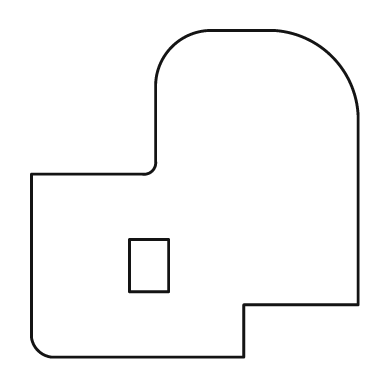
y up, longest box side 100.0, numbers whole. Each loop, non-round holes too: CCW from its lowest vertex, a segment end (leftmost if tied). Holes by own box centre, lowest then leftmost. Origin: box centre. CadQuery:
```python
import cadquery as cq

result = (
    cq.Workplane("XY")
    .moveTo(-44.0, -50.0)
    .lineTo(15.0, -50.0)
    .lineTo(15.0, -34.0)
    .lineTo(50.0, -34.0)
    .lineTo(50.0, 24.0)
    .threePointArc((42.0, 42.0), (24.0, 50.0))
    .lineTo(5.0, 50.0)
    .threePointArc((-7.0, 45.0), (-12.0, 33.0))
    .lineTo(-12.0, 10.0)
    .threePointArc((-13.0, 7.0), (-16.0, 6.0))
    .lineTo(-50.0, 6.0)
    .lineTo(-50.0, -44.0)
    .threePointArc((-48.0, -48.0), (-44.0, -50.0))
    .close()
    .moveTo(-20.0, -30.0)
    .lineTo(-8.0, -30.0)
    .lineTo(-8.0, -14.0)
    .lineTo(-20.0, -14.0)
    .close()
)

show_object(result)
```